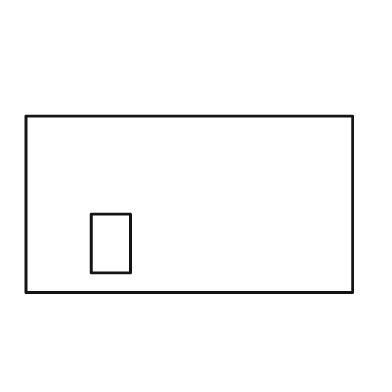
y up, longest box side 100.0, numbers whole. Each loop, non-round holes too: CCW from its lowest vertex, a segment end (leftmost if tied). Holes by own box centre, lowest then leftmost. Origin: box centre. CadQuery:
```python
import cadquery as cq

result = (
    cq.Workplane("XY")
    .moveTo(-50.0, -27.0)
    .lineTo(50.0, -27.0)
    .lineTo(50.0, 27.0)
    .lineTo(-50.0, 27.0)
    .close()
    .moveTo(-30.0, -21.0)
    .lineTo(-18.0, -21.0)
    .lineTo(-18.0, -3.0)
    .lineTo(-30.0, -3.0)
    .close()
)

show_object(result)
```